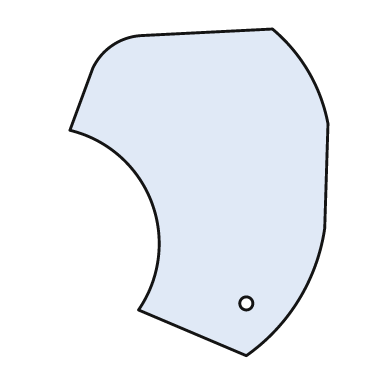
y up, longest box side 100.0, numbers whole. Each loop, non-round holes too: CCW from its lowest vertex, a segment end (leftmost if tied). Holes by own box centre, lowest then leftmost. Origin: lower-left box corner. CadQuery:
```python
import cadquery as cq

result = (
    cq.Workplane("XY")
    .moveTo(54.0, 0.0)
    .threePointArc((70.0, 17.0), (78.0, 39.0))
    .lineTo(79.0, 71.0)
    .threePointArc((73.0, 87.0), (62.0, 100.0))
    .lineTo(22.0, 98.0)
    .threePointArc((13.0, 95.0), (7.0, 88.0))
    .lineTo(0.0, 69.0)
    .threePointArc((25.0, 47.0), (21.0, 14.0))
    .close()
    .moveTo(54.0, 16.0)
    .circle(2.0)
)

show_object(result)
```